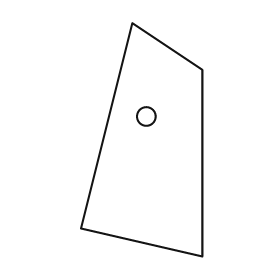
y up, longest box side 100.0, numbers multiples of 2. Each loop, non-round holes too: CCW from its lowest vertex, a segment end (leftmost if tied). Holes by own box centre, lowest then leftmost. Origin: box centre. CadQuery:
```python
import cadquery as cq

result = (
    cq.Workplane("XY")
    .moveTo(26.0, -50.0)
    .lineTo(26.0, 30.0)
    .lineTo(-4.0, 50.0)
    .lineTo(-26.0, -38.0)
    .close()
    .moveTo(2.0, 10.0)
    .circle(4.0)
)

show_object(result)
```